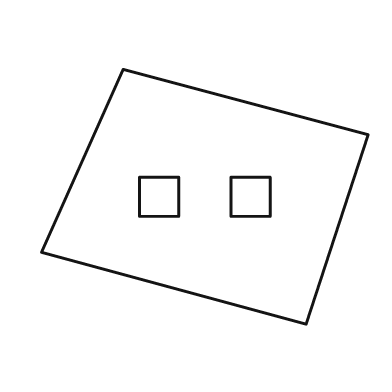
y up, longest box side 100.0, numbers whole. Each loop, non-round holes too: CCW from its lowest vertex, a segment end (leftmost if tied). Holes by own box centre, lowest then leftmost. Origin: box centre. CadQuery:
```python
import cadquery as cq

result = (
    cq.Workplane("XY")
    .moveTo(31.0, -39.0)
    .lineTo(50.0, 19.0)
    .lineTo(-25.0, 39.0)
    .lineTo(-50.0, -17.0)
    .close()
    .moveTo(-20.0, -6.0)
    .lineTo(-8.0, -6.0)
    .lineTo(-8.0, 6.0)
    .lineTo(-20.0, 6.0)
    .close()
    .moveTo(8.0, -6.0)
    .lineTo(20.0, -6.0)
    .lineTo(20.0, 6.0)
    .lineTo(8.0, 6.0)
    .close()
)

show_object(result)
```